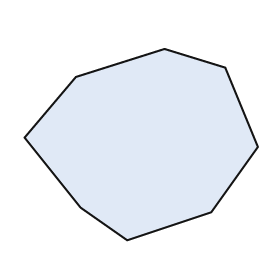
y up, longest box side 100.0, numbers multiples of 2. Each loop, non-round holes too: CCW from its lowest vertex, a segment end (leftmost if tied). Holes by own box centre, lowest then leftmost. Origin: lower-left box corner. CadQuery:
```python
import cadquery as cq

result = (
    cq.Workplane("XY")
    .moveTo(44.0, 0.0)
    .lineTo(80.0, 12.0)
    .lineTo(100.0, 40.0)
    .lineTo(86.0, 74.0)
    .lineTo(60.0, 82.0)
    .lineTo(22.0, 70.0)
    .lineTo(0.0, 44.0)
    .lineTo(24.0, 14.0)
    .close()
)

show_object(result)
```